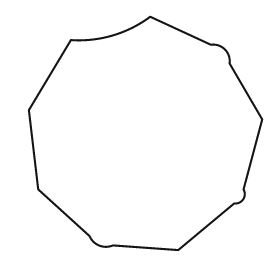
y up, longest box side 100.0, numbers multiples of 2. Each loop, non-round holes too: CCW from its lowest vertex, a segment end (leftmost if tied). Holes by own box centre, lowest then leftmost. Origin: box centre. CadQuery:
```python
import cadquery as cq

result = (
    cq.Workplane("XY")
    .moveTo(14.0, -50.0)
    .lineTo(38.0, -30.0)
    .threePointArc((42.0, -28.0), (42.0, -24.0))
    .lineTo(50.0, 6.0)
    .lineTo(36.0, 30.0)
    .threePointArc((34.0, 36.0), (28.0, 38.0))
    .lineTo(2.0, 50.0)
    .threePointArc((-14.0, 42.0), (-32.0, 40.0))
    .lineTo(-50.0, 10.0)
    .lineTo(-46.0, -24.0)
    .lineTo(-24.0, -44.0)
    .threePointArc((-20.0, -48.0), (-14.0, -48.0))
    .close()
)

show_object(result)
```